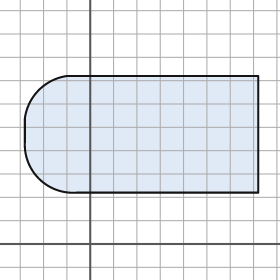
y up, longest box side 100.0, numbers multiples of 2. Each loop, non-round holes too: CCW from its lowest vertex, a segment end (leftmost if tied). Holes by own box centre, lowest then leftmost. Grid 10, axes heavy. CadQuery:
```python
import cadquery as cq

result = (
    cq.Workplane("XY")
    .moveTo(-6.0, 22.0)
    .lineTo(72.0, 22.0)
    .lineTo(72.0, 72.0)
    .lineTo(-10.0, 72.0)
    .threePointArc((-22.0, 66.0), (-28.0, 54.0))
    .lineTo(-28.0, 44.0)
    .threePointArc((-22.0, 28.0), (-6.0, 22.0))
    .close()
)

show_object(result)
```